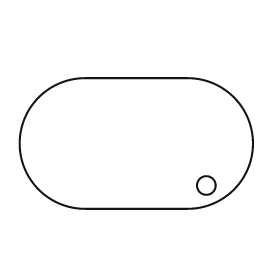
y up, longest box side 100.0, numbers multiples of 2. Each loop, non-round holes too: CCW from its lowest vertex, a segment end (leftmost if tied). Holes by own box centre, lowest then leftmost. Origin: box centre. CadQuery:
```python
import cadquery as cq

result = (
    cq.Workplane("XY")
    .moveTo(-22.0, -28.0)
    .lineTo(22.0, -28.0)
    .threePointArc((50.0, 0.0), (22.0, 28.0))
    .lineTo(-22.0, 28.0)
    .threePointArc((-50.0, 0.0), (-22.0, -28.0))
    .close()
    .moveTo(30.0, -18.0)
    .circle(4.0)
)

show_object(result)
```